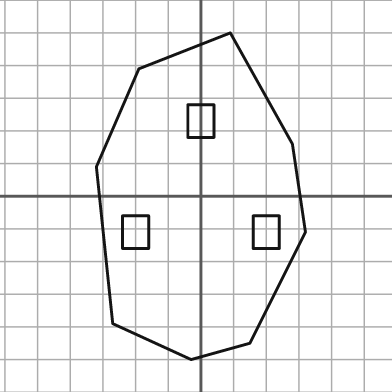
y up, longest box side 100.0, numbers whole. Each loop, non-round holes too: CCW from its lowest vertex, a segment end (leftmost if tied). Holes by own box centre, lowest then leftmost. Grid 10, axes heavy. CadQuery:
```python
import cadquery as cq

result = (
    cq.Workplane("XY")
    .moveTo(-3.0, -50.0)
    .lineTo(15.0, -45.0)
    .lineTo(32.0, -11.0)
    .lineTo(28.0, 16.0)
    .lineTo(9.0, 50.0)
    .lineTo(-19.0, 39.0)
    .lineTo(-32.0, 9.0)
    .lineTo(-27.0, -39.0)
    .close()
    .moveTo(-24.0, -16.0)
    .lineTo(-16.0, -16.0)
    .lineTo(-16.0, -6.0)
    .lineTo(-24.0, -6.0)
    .close()
    .moveTo(16.0, -16.0)
    .lineTo(24.0, -16.0)
    .lineTo(24.0, -6.0)
    .lineTo(16.0, -6.0)
    .close()
    .moveTo(-4.0, 18.0)
    .lineTo(4.0, 18.0)
    .lineTo(4.0, 28.0)
    .lineTo(-4.0, 28.0)
    .close()
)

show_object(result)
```